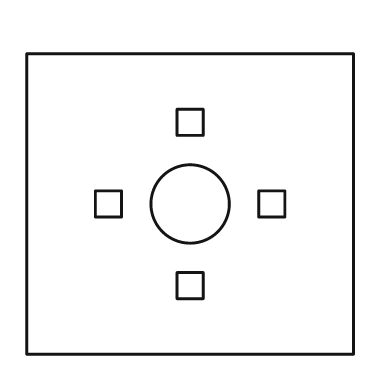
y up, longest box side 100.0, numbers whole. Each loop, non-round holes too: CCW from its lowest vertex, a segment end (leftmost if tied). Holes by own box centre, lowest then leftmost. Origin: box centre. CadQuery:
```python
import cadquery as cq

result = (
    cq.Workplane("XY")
    .moveTo(-50.0, -46.0)
    .lineTo(50.0, -46.0)
    .lineTo(50.0, 46.0)
    .lineTo(-50.0, 46.0)
    .close()
    .moveTo(-4.0, -29.0)
    .lineTo(4.0, -29.0)
    .lineTo(4.0, -21.0)
    .lineTo(-4.0, -21.0)
    .close()
    .moveTo(-29.0, -4.0)
    .lineTo(-21.0, -4.0)
    .lineTo(-21.0, 4.0)
    .lineTo(-29.0, 4.0)
    .close()
    .moveTo(0.0, 0.0)
    .circle(12.0)
    .moveTo(21.0, -4.0)
    .lineTo(29.0, -4.0)
    .lineTo(29.0, 4.0)
    .lineTo(21.0, 4.0)
    .close()
    .moveTo(-4.0, 21.0)
    .lineTo(4.0, 21.0)
    .lineTo(4.0, 29.0)
    .lineTo(-4.0, 29.0)
    .close()
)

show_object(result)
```